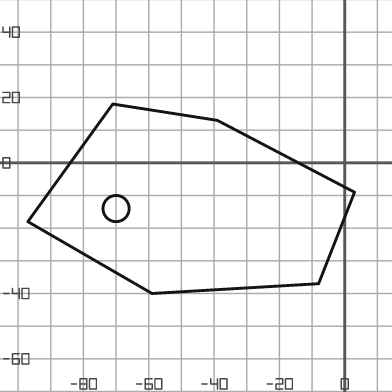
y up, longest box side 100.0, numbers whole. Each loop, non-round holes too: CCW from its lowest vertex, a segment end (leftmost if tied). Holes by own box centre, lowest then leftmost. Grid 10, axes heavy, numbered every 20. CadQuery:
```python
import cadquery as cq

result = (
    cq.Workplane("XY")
    .moveTo(-59.0, -40.0)
    .lineTo(-8.0, -37.0)
    .lineTo(3.0, -9.0)
    .lineTo(-39.0, 13.0)
    .lineTo(-71.0, 18.0)
    .lineTo(-97.0, -18.0)
    .close()
    .moveTo(-70.0, -14.0)
    .circle(4.0)
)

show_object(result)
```